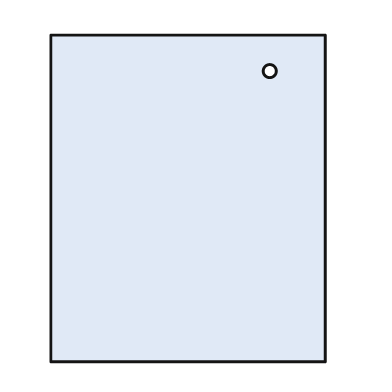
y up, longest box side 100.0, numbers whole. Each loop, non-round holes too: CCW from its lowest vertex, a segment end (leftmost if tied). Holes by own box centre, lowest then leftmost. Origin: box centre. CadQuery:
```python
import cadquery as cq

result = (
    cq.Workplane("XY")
    .moveTo(-42.0, -50.0)
    .lineTo(42.0, -50.0)
    .lineTo(42.0, 50.0)
    .lineTo(-42.0, 50.0)
    .close()
    .moveTo(25.0, 39.0)
    .circle(2.0)
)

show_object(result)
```